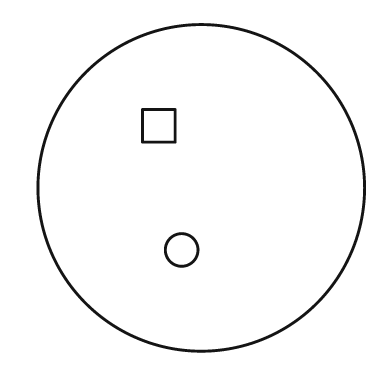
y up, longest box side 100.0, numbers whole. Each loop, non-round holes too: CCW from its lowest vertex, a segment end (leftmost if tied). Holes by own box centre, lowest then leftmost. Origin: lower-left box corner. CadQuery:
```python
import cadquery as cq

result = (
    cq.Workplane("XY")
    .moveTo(50.0, 50.0)
    .circle(50.0)
    .moveTo(44.0, 31.0)
    .circle(5.0)
    .moveTo(32.0, 64.0)
    .lineTo(42.0, 64.0)
    .lineTo(42.0, 74.0)
    .lineTo(32.0, 74.0)
    .close()
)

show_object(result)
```